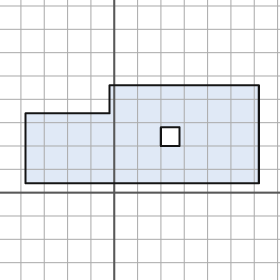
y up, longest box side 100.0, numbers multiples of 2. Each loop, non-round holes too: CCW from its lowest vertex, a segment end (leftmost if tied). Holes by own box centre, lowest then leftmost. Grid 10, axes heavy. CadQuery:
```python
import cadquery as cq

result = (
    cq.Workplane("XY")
    .moveTo(-38.0, 4.0)
    .lineTo(62.0, 4.0)
    .lineTo(62.0, 46.0)
    .lineTo(-2.0, 46.0)
    .lineTo(-2.0, 34.0)
    .lineTo(-38.0, 34.0)
    .close()
    .moveTo(20.0, 20.0)
    .lineTo(28.0, 20.0)
    .lineTo(28.0, 28.0)
    .lineTo(20.0, 28.0)
    .close()
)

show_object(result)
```